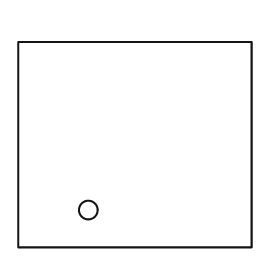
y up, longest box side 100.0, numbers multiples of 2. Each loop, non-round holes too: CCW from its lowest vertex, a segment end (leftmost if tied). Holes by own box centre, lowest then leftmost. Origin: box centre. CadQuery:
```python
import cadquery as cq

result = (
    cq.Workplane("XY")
    .moveTo(-50.0, -44.0)
    .lineTo(50.0, -44.0)
    .lineTo(50.0, 44.0)
    .lineTo(-50.0, 44.0)
    .close()
    .moveTo(-20.0, -28.0)
    .circle(4.0)
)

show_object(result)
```